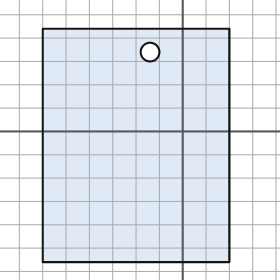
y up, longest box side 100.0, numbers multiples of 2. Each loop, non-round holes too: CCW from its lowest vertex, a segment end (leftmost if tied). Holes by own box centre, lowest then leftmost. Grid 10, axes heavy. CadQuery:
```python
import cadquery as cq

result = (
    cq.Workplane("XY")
    .moveTo(-60.0, -56.0)
    .lineTo(20.0, -56.0)
    .lineTo(20.0, 44.0)
    .lineTo(-60.0, 44.0)
    .close()
    .moveTo(-14.0, 34.0)
    .circle(4.0)
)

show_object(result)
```